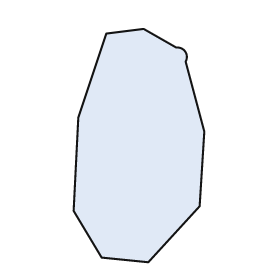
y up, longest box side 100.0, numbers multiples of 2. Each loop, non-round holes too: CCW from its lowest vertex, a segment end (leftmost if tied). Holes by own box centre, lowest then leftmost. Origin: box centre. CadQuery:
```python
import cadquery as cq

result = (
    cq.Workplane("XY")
    .moveTo(4.0, -50.0)
    .lineTo(26.0, -26.0)
    .lineTo(28.0, 6.0)
    .lineTo(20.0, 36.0)
    .threePointArc((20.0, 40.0), (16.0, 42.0))
    .lineTo(2.0, 50.0)
    .lineTo(-14.0, 48.0)
    .lineTo(-26.0, 12.0)
    .lineTo(-28.0, -28.0)
    .lineTo(-16.0, -48.0)
    .close()
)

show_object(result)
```